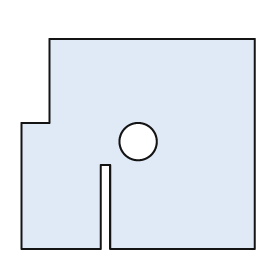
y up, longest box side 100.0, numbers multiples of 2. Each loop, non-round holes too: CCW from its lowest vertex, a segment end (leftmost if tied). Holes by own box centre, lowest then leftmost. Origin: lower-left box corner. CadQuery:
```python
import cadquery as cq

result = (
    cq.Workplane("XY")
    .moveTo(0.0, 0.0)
    .lineTo(34.0, 0.0)
    .lineTo(34.0, 36.0)
    .lineTo(38.0, 36.0)
    .lineTo(38.0, 0.0)
    .lineTo(100.0, 0.0)
    .lineTo(100.0, 90.0)
    .lineTo(12.0, 90.0)
    .lineTo(12.0, 54.0)
    .lineTo(0.0, 54.0)
    .close()
    .moveTo(50.0, 46.0)
    .circle(8.0)
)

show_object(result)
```